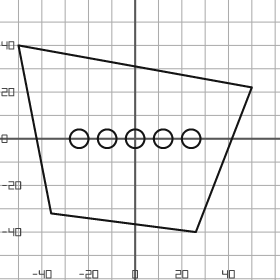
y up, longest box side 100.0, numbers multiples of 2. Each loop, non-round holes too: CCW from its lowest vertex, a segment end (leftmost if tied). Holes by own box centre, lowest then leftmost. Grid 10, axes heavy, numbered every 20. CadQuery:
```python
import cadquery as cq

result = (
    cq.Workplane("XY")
    .moveTo(26.0, -40.0)
    .lineTo(50.0, 22.0)
    .lineTo(-50.0, 40.0)
    .lineTo(-36.0, -32.0)
    .close()
    .moveTo(-24.0, 0.0)
    .circle(4.0)
    .moveTo(-12.0, 0.0)
    .circle(4.0)
    .moveTo(0.0, 0.0)
    .circle(4.0)
    .moveTo(12.0, 0.0)
    .circle(4.0)
    .moveTo(24.0, 0.0)
    .circle(4.0)
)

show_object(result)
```